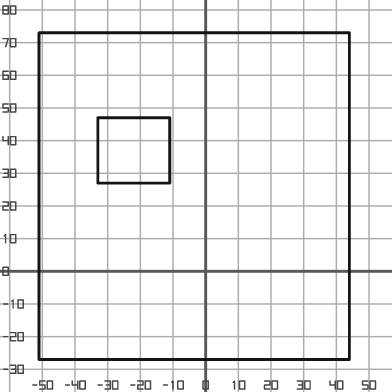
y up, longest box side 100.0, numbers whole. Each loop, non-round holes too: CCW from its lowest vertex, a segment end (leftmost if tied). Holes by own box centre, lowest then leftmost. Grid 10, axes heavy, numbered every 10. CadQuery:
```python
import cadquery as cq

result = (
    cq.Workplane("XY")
    .moveTo(-51.0, -27.0)
    .lineTo(44.0, -27.0)
    .lineTo(44.0, 73.0)
    .lineTo(-51.0, 73.0)
    .close()
    .moveTo(-33.0, 27.0)
    .lineTo(-11.0, 27.0)
    .lineTo(-11.0, 47.0)
    .lineTo(-33.0, 47.0)
    .close()
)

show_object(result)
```